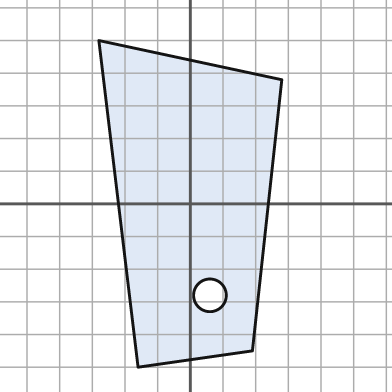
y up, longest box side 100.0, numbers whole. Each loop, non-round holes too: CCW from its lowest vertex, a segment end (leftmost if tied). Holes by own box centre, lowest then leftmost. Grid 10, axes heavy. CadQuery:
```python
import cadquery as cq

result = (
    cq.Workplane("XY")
    .moveTo(-16.0, -50.0)
    .lineTo(19.0, -45.0)
    .lineTo(28.0, 38.0)
    .lineTo(-28.0, 50.0)
    .close()
    .moveTo(6.0, -28.0)
    .circle(5.0)
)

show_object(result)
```